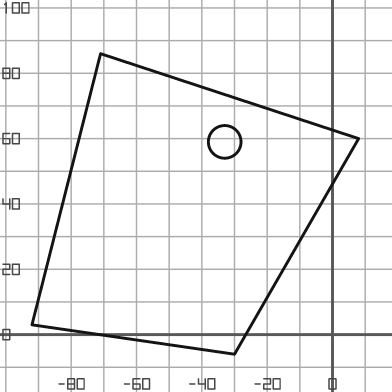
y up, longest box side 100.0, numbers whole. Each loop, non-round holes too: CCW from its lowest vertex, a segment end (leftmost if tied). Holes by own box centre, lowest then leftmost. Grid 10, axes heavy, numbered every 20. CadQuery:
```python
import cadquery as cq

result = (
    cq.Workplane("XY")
    .moveTo(-30.0, -6.0)
    .lineTo(8.0, 60.0)
    .lineTo(-71.0, 86.0)
    .lineTo(-92.0, 3.0)
    .close()
    .moveTo(-33.0, 59.0)
    .circle(5.0)
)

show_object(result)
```